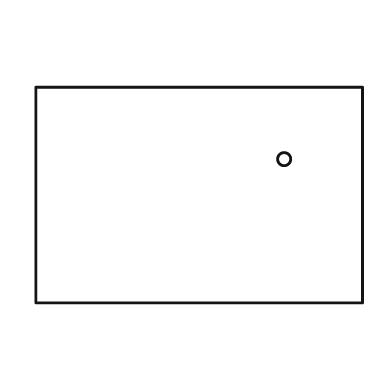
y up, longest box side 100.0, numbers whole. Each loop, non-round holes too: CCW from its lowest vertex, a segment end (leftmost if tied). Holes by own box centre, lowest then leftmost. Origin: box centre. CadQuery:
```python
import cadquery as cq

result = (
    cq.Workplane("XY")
    .moveTo(-50.0, -33.0)
    .lineTo(50.0, -33.0)
    .lineTo(50.0, 33.0)
    .lineTo(-50.0, 33.0)
    .close()
    .moveTo(26.0, 11.0)
    .circle(2.0)
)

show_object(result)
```